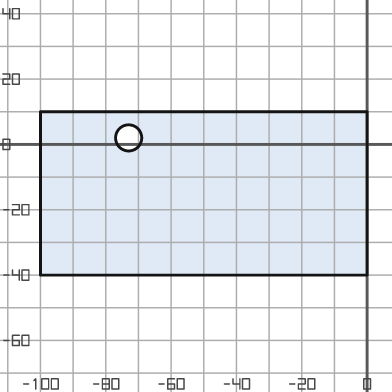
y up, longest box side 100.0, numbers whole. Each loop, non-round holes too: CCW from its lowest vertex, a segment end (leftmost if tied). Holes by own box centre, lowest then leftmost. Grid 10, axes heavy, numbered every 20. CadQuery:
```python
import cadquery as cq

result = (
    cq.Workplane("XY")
    .moveTo(-100.0, -40.0)
    .lineTo(0.0, -40.0)
    .lineTo(0.0, 10.0)
    .lineTo(-100.0, 10.0)
    .close()
    .moveTo(-73.0, 2.0)
    .circle(4.0)
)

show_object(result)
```